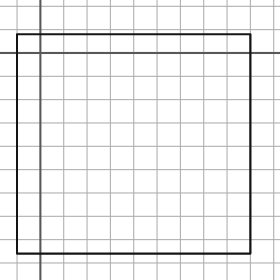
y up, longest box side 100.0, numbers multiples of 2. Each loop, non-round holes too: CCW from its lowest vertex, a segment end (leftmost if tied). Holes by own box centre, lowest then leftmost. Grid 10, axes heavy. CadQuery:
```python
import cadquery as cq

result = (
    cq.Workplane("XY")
    .moveTo(-10.0, -86.0)
    .lineTo(90.0, -86.0)
    .lineTo(90.0, 8.0)
    .lineTo(-10.0, 8.0)
    .close()
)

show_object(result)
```